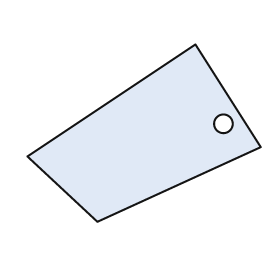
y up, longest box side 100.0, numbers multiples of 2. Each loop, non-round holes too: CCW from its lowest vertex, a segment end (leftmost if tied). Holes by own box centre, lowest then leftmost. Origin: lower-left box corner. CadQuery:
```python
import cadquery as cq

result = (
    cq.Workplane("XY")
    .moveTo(30.0, 0.0)
    .lineTo(100.0, 32.0)
    .lineTo(72.0, 76.0)
    .lineTo(0.0, 28.0)
    .close()
    .moveTo(84.0, 42.0)
    .circle(4.0)
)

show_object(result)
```